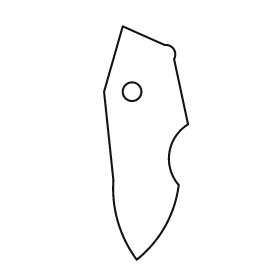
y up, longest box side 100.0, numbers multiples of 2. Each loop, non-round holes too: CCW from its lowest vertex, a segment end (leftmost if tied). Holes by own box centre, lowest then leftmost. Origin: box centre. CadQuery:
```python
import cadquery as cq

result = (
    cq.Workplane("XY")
    .moveTo(-4.0, -50.0)
    .threePointArc((8.0, -36.0), (14.0, -18.0))
    .threePointArc((10.0, -4.0), (18.0, 8.0))
    .lineTo(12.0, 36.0)
    .threePointArc((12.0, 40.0), (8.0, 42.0))
    .lineTo(-10.0, 50.0)
    .lineTo(-18.0, 22.0)
    .lineTo(-14.0, -16.0)
    .threePointArc((-12.0, -34.0), (-4.0, -50.0))
    .close()
    .moveTo(-6.0, 22.0)
    .circle(4.0)
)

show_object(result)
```